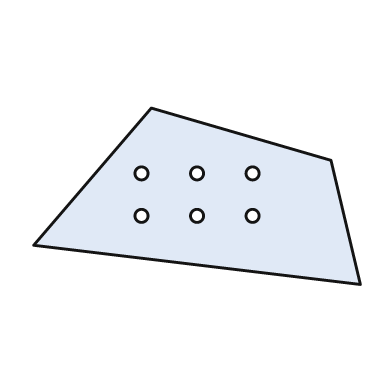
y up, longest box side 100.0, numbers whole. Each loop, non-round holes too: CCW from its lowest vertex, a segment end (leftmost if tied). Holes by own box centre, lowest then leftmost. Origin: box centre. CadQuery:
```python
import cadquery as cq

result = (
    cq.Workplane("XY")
    .moveTo(50.0, -27.0)
    .lineTo(41.0, 11.0)
    .lineTo(-14.0, 27.0)
    .lineTo(-50.0, -15.0)
    .close()
    .moveTo(-17.0, -6.0)
    .circle(2.0)
    .moveTo(0.0, -6.0)
    .circle(2.0)
    .moveTo(17.0, -6.0)
    .circle(2.0)
    .moveTo(-17.0, 7.0)
    .circle(2.0)
    .moveTo(0.0, 7.0)
    .circle(2.0)
    .moveTo(17.0, 7.0)
    .circle(2.0)
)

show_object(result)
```